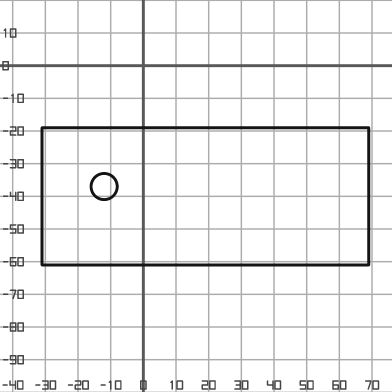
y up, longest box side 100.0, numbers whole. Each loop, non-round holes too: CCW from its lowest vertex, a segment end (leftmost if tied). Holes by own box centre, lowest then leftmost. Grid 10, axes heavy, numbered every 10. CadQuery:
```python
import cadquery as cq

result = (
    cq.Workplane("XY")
    .moveTo(-31.0, -61.0)
    .lineTo(69.0, -61.0)
    .lineTo(69.0, -19.0)
    .lineTo(-31.0, -19.0)
    .close()
    .moveTo(-12.0, -37.0)
    .circle(4.0)
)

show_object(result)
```